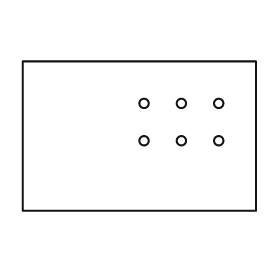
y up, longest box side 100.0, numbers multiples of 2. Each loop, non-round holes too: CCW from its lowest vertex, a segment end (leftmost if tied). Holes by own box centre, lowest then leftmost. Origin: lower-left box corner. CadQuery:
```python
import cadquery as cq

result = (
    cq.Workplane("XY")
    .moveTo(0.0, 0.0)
    .lineTo(100.0, 0.0)
    .lineTo(100.0, 64.0)
    .lineTo(0.0, 64.0)
    .close()
    .moveTo(52.0, 30.0)
    .circle(2.0)
    .moveTo(68.0, 30.0)
    .circle(2.0)
    .moveTo(84.0, 30.0)
    .circle(2.0)
    .moveTo(52.0, 46.0)
    .circle(2.0)
    .moveTo(68.0, 46.0)
    .circle(2.0)
    .moveTo(84.0, 46.0)
    .circle(2.0)
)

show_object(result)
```